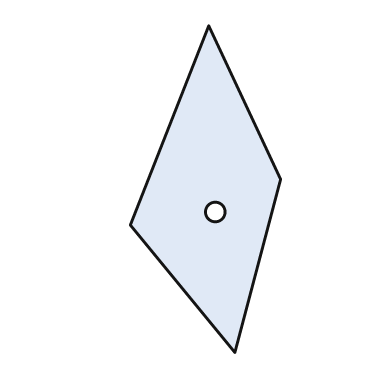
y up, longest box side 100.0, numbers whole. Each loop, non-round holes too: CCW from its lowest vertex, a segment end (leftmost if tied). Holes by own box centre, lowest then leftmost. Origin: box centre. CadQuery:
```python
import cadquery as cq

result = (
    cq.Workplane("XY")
    .moveTo(9.0, -50.0)
    .lineTo(23.0, 3.0)
    .lineTo(1.0, 50.0)
    .lineTo(-23.0, -11.0)
    .close()
    .moveTo(3.0, -7.0)
    .circle(3.0)
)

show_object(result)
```